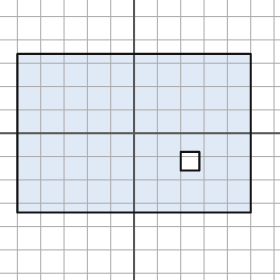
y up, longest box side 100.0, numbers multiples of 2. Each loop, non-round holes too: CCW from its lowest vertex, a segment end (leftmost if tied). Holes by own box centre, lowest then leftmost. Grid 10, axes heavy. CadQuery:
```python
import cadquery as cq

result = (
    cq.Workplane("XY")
    .moveTo(-50.0, -34.0)
    .lineTo(50.0, -34.0)
    .lineTo(50.0, 34.0)
    .lineTo(-50.0, 34.0)
    .close()
    .moveTo(20.0, -16.0)
    .lineTo(28.0, -16.0)
    .lineTo(28.0, -8.0)
    .lineTo(20.0, -8.0)
    .close()
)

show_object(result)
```